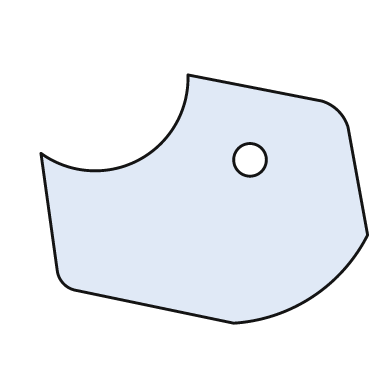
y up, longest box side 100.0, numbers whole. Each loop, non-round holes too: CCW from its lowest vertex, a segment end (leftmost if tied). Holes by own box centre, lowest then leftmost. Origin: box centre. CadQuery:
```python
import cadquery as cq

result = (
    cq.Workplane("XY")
    .moveTo(9.0, -38.0)
    .threePointArc((33.0, -30.0), (50.0, -11.0))
    .lineTo(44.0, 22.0)
    .threePointArc((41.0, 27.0), (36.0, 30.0))
    .lineTo(-5.0, 38.0)
    .threePointArc((-20.0, 12.0), (-50.0, 14.0))
    .lineTo(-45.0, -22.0)
    .threePointArc((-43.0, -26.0), (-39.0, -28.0))
    .close()
    .moveTo(14.0, 12.0)
    .circle(5.0)
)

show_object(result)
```